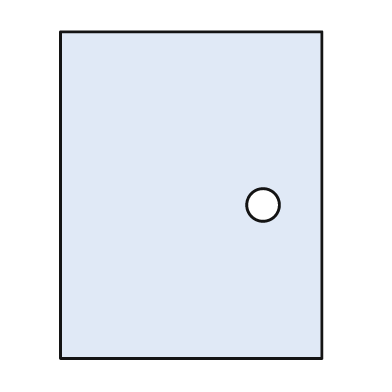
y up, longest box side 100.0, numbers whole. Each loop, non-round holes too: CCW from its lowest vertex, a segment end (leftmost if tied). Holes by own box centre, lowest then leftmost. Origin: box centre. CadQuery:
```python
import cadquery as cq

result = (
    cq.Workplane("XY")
    .moveTo(-40.0, -50.0)
    .lineTo(40.0, -50.0)
    .lineTo(40.0, 50.0)
    .lineTo(-40.0, 50.0)
    .close()
    .moveTo(22.0, -3.0)
    .circle(5.0)
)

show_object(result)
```